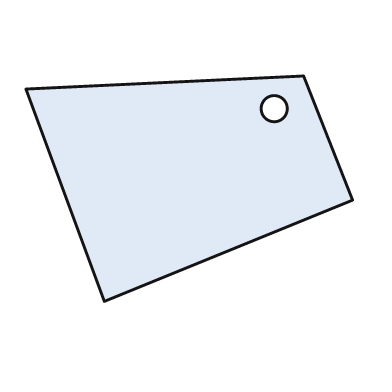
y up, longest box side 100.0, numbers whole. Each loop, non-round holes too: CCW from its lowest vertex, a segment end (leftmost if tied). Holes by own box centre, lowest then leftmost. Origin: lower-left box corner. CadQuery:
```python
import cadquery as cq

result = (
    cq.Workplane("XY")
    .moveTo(24.0, 0.0)
    .lineTo(100.0, 31.0)
    .lineTo(85.0, 69.0)
    .lineTo(0.0, 65.0)
    .close()
    .moveTo(76.0, 59.0)
    .circle(4.0)
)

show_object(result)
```